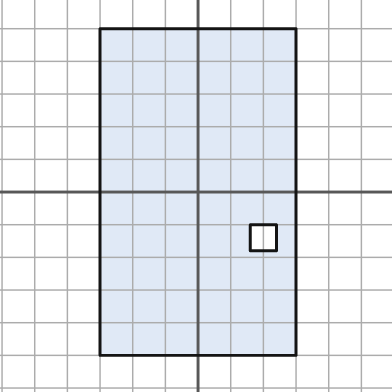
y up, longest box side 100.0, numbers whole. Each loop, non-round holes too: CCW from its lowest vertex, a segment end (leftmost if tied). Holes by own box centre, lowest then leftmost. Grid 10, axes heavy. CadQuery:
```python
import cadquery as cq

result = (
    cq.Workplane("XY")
    .moveTo(-30.0, -50.0)
    .lineTo(30.0, -50.0)
    .lineTo(30.0, 50.0)
    .lineTo(-30.0, 50.0)
    .close()
    .moveTo(16.0, -18.0)
    .lineTo(24.0, -18.0)
    .lineTo(24.0, -10.0)
    .lineTo(16.0, -10.0)
    .close()
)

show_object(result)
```